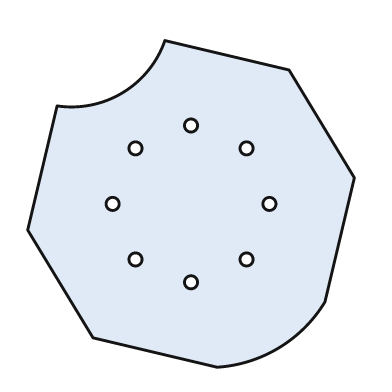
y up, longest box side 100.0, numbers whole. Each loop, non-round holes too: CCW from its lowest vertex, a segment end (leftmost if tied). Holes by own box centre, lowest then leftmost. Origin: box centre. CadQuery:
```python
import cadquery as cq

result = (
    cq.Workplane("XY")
    .moveTo(8.0, -50.0)
    .threePointArc((27.0, -44.0), (41.0, -30.0))
    .lineTo(50.0, 8.0)
    .lineTo(30.0, 41.0)
    .lineTo(-8.0, 50.0)
    .threePointArc((-21.0, 34.0), (-41.0, 30.0))
    .lineTo(-50.0, -8.0)
    .lineTo(-30.0, -41.0)
    .close()
    .moveTo(0.0, -24.0)
    .circle(2.0)
    .moveTo(-17.0, -17.0)
    .circle(2.0)
    .moveTo(17.0, -17.0)
    .circle(2.0)
    .moveTo(-24.0, 0.0)
    .circle(2.0)
    .moveTo(24.0, 0.0)
    .circle(2.0)
    .moveTo(-17.0, 17.0)
    .circle(2.0)
    .moveTo(17.0, 17.0)
    .circle(2.0)
    .moveTo(0.0, 24.0)
    .circle(2.0)
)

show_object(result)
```